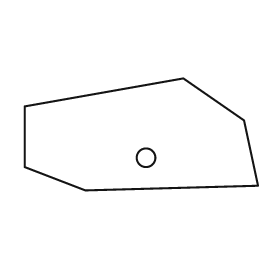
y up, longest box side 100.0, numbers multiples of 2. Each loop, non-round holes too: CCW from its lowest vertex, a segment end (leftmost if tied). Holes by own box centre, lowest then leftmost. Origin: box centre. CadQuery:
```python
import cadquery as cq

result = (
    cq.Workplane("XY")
    .moveTo(-24.0, -24.0)
    .lineTo(50.0, -22.0)
    .lineTo(44.0, 6.0)
    .lineTo(18.0, 24.0)
    .lineTo(-50.0, 12.0)
    .lineTo(-50.0, -14.0)
    .close()
    .moveTo(2.0, -10.0)
    .circle(4.0)
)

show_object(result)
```